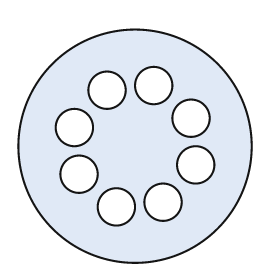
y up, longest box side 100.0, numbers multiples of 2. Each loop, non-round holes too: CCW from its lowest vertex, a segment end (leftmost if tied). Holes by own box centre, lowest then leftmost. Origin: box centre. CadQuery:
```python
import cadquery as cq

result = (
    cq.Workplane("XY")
    .moveTo(0.0, 0.0)
    .circle(50.0)
    .moveTo(-8.0, -26.0)
    .circle(8.0)
    .moveTo(12.0, -24.0)
    .circle(8.0)
    .moveTo(-24.0, -12.0)
    .circle(8.0)
    .moveTo(26.0, -8.0)
    .circle(8.0)
    .moveTo(-26.0, 8.0)
    .circle(8.0)
    .moveTo(24.0, 12.0)
    .circle(8.0)
    .moveTo(-12.0, 24.0)
    .circle(8.0)
    .moveTo(8.0, 26.0)
    .circle(8.0)
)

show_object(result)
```